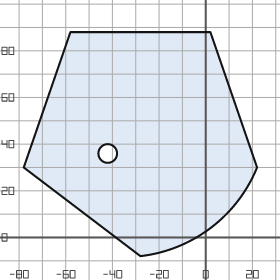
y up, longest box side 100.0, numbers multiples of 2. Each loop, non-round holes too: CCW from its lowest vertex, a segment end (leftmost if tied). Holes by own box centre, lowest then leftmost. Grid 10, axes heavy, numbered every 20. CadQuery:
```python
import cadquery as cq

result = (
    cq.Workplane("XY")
    .moveTo(-28.0, -8.0)
    .threePointArc((2.0, 4.0), (22.0, 30.0))
    .lineTo(2.0, 88.0)
    .lineTo(-58.0, 88.0)
    .lineTo(-78.0, 30.0)
    .close()
    .moveTo(-42.0, 36.0)
    .circle(4.0)
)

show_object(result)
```